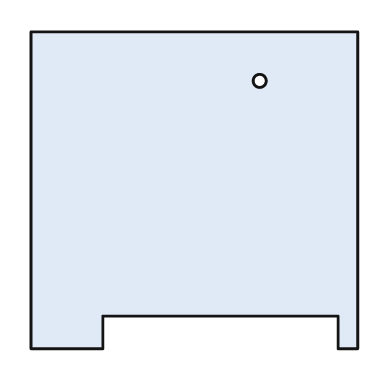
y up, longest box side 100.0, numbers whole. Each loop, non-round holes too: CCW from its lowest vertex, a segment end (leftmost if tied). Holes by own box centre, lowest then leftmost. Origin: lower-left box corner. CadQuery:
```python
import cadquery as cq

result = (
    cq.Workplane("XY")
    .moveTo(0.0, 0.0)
    .lineTo(22.0, 0.0)
    .lineTo(22.0, 10.0)
    .lineTo(94.0, 10.0)
    .lineTo(94.0, 0.0)
    .lineTo(100.0, 0.0)
    .lineTo(100.0, 97.0)
    .lineTo(0.0, 97.0)
    .close()
    .moveTo(70.0, 82.0)
    .circle(2.0)
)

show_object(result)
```